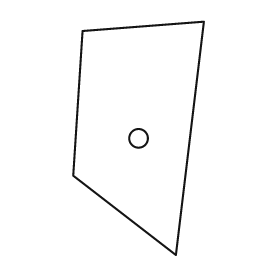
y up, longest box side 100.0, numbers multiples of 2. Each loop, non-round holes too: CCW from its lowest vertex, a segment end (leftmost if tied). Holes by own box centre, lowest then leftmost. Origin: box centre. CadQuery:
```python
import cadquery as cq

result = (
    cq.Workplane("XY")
    .moveTo(16.0, -50.0)
    .lineTo(28.0, 50.0)
    .lineTo(-24.0, 46.0)
    .lineTo(-28.0, -16.0)
    .close()
    .moveTo(0.0, 0.0)
    .circle(4.0)
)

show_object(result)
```